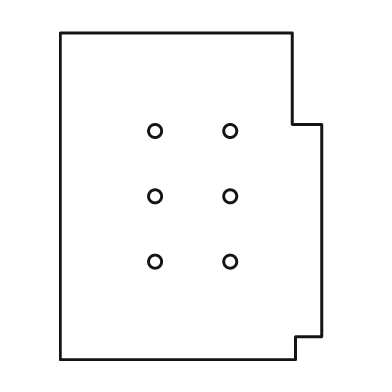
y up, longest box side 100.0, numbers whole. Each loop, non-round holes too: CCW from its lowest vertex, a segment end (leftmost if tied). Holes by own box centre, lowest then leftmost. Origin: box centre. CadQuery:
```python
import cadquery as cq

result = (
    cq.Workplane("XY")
    .moveTo(-40.0, -50.0)
    .lineTo(32.0, -50.0)
    .lineTo(32.0, -43.0)
    .lineTo(40.0, -43.0)
    .lineTo(40.0, 22.0)
    .lineTo(31.0, 22.0)
    .lineTo(31.0, 50.0)
    .lineTo(-40.0, 50.0)
    .close()
    .moveTo(-11.0, -20.0)
    .circle(2.0)
    .moveTo(12.0, -20.0)
    .circle(2.0)
    .moveTo(-11.0, 0.0)
    .circle(2.0)
    .moveTo(12.0, 0.0)
    .circle(2.0)
    .moveTo(-11.0, 20.0)
    .circle(2.0)
    .moveTo(12.0, 20.0)
    .circle(2.0)
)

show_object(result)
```